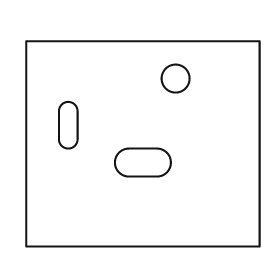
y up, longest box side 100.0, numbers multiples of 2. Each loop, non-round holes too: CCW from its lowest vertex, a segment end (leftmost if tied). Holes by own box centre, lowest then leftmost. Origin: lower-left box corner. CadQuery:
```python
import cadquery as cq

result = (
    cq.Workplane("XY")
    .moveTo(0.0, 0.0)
    .lineTo(100.0, 0.0)
    .lineTo(100.0, 88.0)
    .lineTo(0.0, 88.0)
    .close()
    .moveTo(44.0, 30.0)
    .lineTo(56.0, 30.0)
    .threePointArc((62.0, 36.0), (56.0, 42.0))
    .lineTo(44.0, 42.0)
    .threePointArc((38.0, 36.0), (44.0, 30.0))
    .close()
    .moveTo(14.0, 46.0)
    .threePointArc((18.0, 42.0), (22.0, 46.0))
    .lineTo(22.0, 58.0)
    .threePointArc((18.0, 62.0), (14.0, 58.0))
    .close()
    .moveTo(64.0, 72.0)
    .circle(6.0)
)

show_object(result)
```